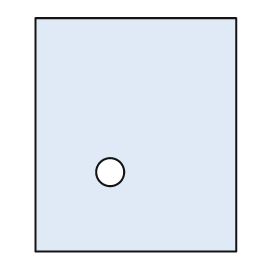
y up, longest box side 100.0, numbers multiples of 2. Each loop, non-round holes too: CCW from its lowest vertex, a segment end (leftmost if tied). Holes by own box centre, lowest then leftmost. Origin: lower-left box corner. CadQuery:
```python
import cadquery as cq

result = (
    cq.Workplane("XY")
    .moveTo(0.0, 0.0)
    .lineTo(86.0, 0.0)
    .lineTo(86.0, 100.0)
    .lineTo(0.0, 100.0)
    .close()
    .moveTo(32.0, 34.0)
    .circle(6.0)
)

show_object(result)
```